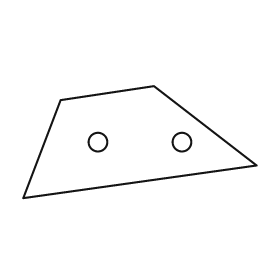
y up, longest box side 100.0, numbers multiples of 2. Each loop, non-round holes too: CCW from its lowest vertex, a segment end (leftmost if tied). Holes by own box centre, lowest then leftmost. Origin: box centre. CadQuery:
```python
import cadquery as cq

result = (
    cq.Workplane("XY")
    .moveTo(-50.0, -24.0)
    .lineTo(50.0, -10.0)
    .lineTo(6.0, 24.0)
    .lineTo(-34.0, 18.0)
    .close()
    .moveTo(-18.0, 0.0)
    .circle(4.0)
    .moveTo(18.0, 0.0)
    .circle(4.0)
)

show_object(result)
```